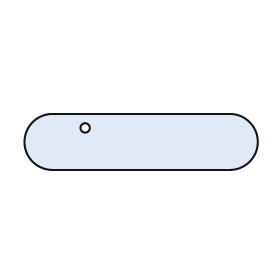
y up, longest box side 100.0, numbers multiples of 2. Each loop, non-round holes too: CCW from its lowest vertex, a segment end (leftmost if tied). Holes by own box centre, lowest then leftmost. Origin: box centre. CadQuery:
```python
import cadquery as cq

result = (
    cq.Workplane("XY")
    .moveTo(-38.0, -12.0)
    .lineTo(38.0, -12.0)
    .threePointArc((50.0, 0.0), (38.0, 12.0))
    .lineTo(-38.0, 12.0)
    .threePointArc((-50.0, 0.0), (-38.0, -12.0))
    .close()
    .moveTo(-24.0, 6.0)
    .circle(2.0)
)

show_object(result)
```